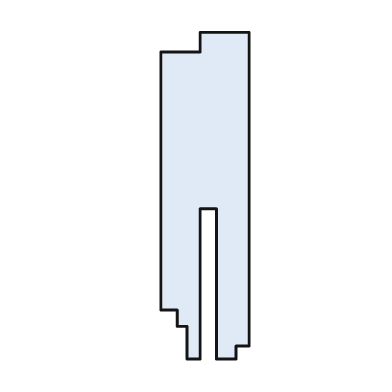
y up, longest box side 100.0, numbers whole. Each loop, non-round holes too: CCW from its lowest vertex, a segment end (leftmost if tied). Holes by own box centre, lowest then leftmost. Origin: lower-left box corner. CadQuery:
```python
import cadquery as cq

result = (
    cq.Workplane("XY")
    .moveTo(8.0, 0.0)
    .lineTo(12.0, 0.0)
    .lineTo(12.0, 46.0)
    .lineTo(17.0, 46.0)
    .lineTo(17.0, 0.0)
    .lineTo(23.0, 0.0)
    .lineTo(23.0, 4.0)
    .lineTo(27.0, 4.0)
    .lineTo(27.0, 100.0)
    .lineTo(12.0, 100.0)
    .lineTo(12.0, 94.0)
    .lineTo(0.0, 94.0)
    .lineTo(0.0, 15.0)
    .lineTo(5.0, 15.0)
    .lineTo(5.0, 10.0)
    .lineTo(8.0, 10.0)
    .close()
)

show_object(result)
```